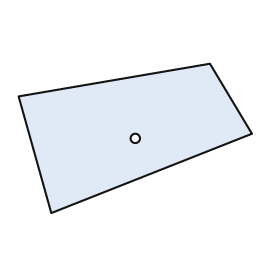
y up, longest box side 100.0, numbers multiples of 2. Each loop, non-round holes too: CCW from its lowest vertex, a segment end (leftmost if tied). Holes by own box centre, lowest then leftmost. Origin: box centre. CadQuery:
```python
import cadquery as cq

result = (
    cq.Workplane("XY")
    .moveTo(-36.0, -32.0)
    .lineTo(50.0, 2.0)
    .lineTo(32.0, 32.0)
    .lineTo(-50.0, 18.0)
    .close()
    .moveTo(0.0, 0.0)
    .circle(2.0)
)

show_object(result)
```